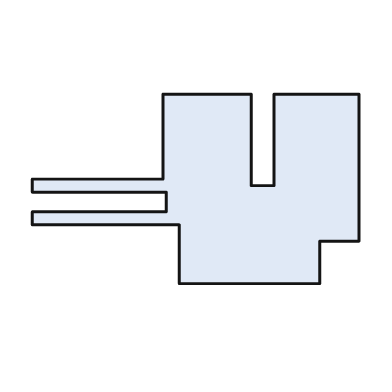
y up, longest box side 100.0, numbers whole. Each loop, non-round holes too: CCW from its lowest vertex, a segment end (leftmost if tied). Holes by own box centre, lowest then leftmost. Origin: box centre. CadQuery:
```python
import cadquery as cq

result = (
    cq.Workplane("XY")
    .moveTo(-5.0, -29.0)
    .lineTo(38.0, -29.0)
    .lineTo(38.0, -16.0)
    .lineTo(50.0, -16.0)
    .lineTo(50.0, 29.0)
    .lineTo(24.0, 29.0)
    .lineTo(24.0, 1.0)
    .lineTo(17.0, 1.0)
    .lineTo(17.0, 29.0)
    .lineTo(-10.0, 29.0)
    .lineTo(-10.0, 3.0)
    .lineTo(-50.0, 3.0)
    .lineTo(-50.0, -1.0)
    .lineTo(-9.0, -1.0)
    .lineTo(-9.0, -7.0)
    .lineTo(-50.0, -7.0)
    .lineTo(-50.0, -11.0)
    .lineTo(-5.0, -11.0)
    .close()
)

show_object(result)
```